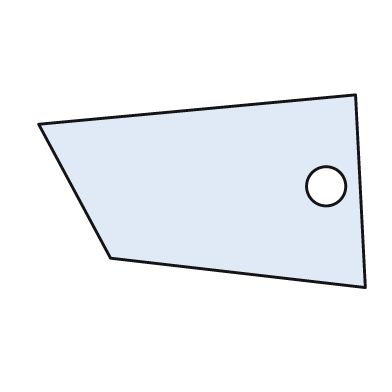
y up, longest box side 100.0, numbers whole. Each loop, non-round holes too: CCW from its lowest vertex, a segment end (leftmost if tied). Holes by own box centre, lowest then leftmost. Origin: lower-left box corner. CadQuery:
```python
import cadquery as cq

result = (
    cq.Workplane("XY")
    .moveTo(100.0, 0.0)
    .lineTo(97.0, 59.0)
    .lineTo(0.0, 50.0)
    .lineTo(22.0, 9.0)
    .close()
    .moveTo(88.0, 31.0)
    .circle(6.0)
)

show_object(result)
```